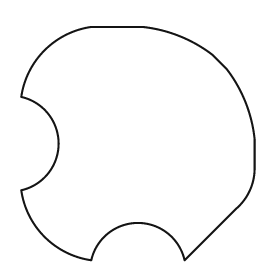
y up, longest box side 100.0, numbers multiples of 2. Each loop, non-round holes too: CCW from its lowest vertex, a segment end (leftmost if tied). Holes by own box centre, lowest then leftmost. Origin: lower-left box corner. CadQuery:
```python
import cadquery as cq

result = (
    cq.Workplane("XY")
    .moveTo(30.0, 0.0)
    .threePointArc((50.0, 16.0), (70.0, 0.0))
    .lineTo(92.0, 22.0)
    .threePointArc((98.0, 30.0), (100.0, 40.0))
    .lineTo(100.0, 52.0)
    .threePointArc((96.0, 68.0), (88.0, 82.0))
    .lineTo(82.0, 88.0)
    .threePointArc((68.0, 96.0), (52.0, 100.0))
    .lineTo(30.0, 100.0)
    .threePointArc((10.0, 90.0), (0.0, 70.0))
    .threePointArc((16.0, 50.0), (0.0, 30.0))
    .threePointArc((10.0, 10.0), (30.0, 0.0))
    .close()
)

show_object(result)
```